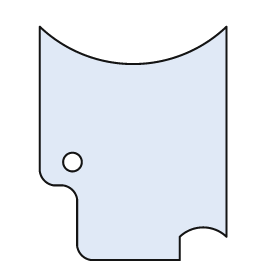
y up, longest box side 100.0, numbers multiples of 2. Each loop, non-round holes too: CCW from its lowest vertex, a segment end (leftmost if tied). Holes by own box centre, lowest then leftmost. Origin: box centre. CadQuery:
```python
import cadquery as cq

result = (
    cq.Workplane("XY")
    .moveTo(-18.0, -50.0)
    .lineTo(20.0, -50.0)
    .lineTo(20.0, -40.0)
    .threePointArc((30.0, -36.0), (40.0, -40.0))
    .lineTo(40.0, 50.0)
    .threePointArc((0.0, 34.0), (-40.0, 50.0))
    .lineTo(-40.0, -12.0)
    .threePointArc((-38.0, -16.0), (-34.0, -18.0))
    .lineTo(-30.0, -18.0)
    .threePointArc((-26.0, -20.0), (-24.0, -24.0))
    .lineTo(-24.0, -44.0)
    .threePointArc((-22.0, -48.0), (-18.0, -50.0))
    .close()
    .moveTo(-26.0, -8.0)
    .circle(4.0)
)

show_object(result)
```